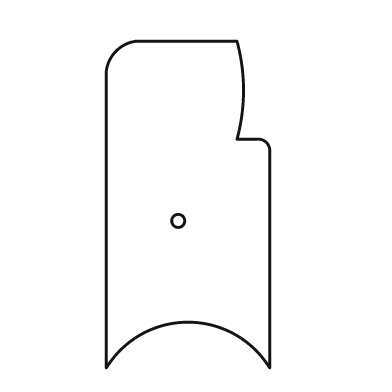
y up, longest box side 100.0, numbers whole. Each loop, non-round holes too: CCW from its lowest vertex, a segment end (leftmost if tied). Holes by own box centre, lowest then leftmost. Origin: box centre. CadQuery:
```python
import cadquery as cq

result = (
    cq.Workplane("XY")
    .moveTo(-25.0, -50.0)
    .threePointArc((0.0, -36.0), (25.0, -50.0))
    .lineTo(25.0, 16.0)
    .threePointArc((24.0, 19.0), (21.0, 20.0))
    .lineTo(15.0, 20.0)
    .threePointArc((17.0, 35.0), (15.0, 50.0))
    .lineTo(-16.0, 50.0)
    .threePointArc((-22.0, 47.0), (-25.0, 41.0))
    .close()
    .moveTo(-3.0, -5.0)
    .circle(2.0)
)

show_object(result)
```